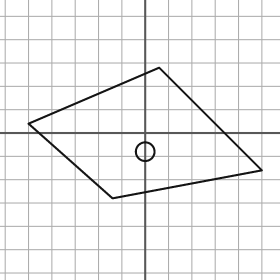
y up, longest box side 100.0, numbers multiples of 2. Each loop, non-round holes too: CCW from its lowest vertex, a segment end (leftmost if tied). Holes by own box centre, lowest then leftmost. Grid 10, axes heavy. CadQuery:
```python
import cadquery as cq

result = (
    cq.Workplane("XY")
    .moveTo(-14.0, -28.0)
    .lineTo(50.0, -16.0)
    .lineTo(6.0, 28.0)
    .lineTo(-50.0, 4.0)
    .close()
    .moveTo(0.0, -8.0)
    .circle(4.0)
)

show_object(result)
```